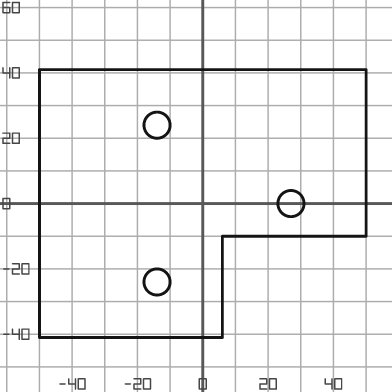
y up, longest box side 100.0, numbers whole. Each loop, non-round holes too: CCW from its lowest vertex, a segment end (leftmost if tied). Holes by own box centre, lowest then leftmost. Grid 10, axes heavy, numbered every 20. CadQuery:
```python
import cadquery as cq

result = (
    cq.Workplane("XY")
    .moveTo(-50.0, -41.0)
    .lineTo(6.0, -41.0)
    .lineTo(6.0, -10.0)
    .lineTo(50.0, -10.0)
    .lineTo(50.0, 41.0)
    .lineTo(-50.0, 41.0)
    .close()
    .moveTo(-14.0, -24.0)
    .circle(4.0)
    .moveTo(27.0, 0.0)
    .circle(4.0)
    .moveTo(-14.0, 24.0)
    .circle(4.0)
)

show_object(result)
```